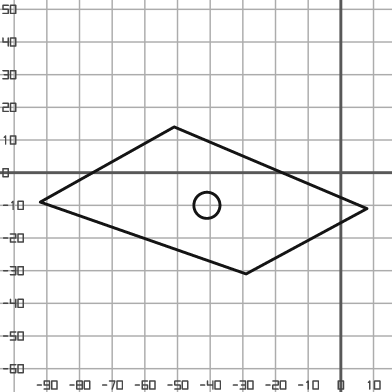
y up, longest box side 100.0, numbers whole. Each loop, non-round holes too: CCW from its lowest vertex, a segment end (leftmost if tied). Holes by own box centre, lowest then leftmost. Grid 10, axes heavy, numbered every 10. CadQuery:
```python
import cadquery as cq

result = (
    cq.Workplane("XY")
    .moveTo(-29.0, -31.0)
    .lineTo(8.0, -11.0)
    .lineTo(-51.0, 14.0)
    .lineTo(-92.0, -9.0)
    .close()
    .moveTo(-41.0, -10.0)
    .circle(4.0)
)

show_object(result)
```